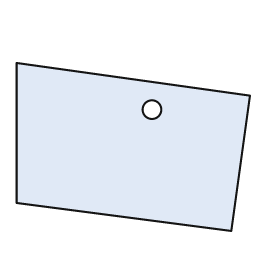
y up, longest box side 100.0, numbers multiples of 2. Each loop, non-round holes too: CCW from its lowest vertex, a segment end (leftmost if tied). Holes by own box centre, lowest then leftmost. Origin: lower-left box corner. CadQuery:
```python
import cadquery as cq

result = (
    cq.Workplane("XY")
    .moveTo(92.0, 0.0)
    .lineTo(100.0, 58.0)
    .lineTo(0.0, 72.0)
    .lineTo(0.0, 12.0)
    .close()
    .moveTo(58.0, 52.0)
    .circle(4.0)
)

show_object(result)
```